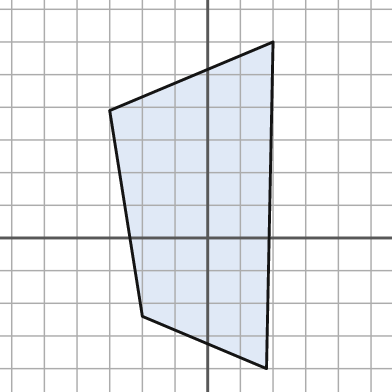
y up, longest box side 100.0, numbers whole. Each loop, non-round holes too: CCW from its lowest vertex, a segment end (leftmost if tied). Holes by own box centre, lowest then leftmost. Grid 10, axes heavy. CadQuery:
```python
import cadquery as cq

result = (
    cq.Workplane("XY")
    .moveTo(18.0, -40.0)
    .lineTo(20.0, 60.0)
    .lineTo(-30.0, 39.0)
    .lineTo(-20.0, -24.0)
    .close()
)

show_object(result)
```